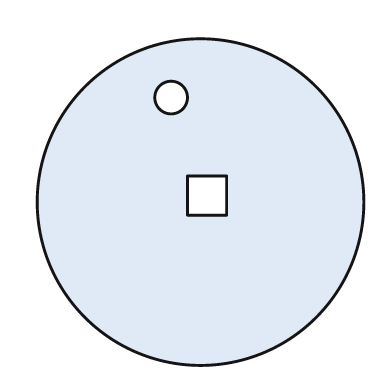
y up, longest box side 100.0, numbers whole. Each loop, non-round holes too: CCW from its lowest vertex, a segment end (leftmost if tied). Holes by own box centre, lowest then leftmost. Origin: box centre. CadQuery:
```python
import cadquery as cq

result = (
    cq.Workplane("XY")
    .moveTo(0.0, 0.0)
    .circle(50.0)
    .moveTo(-4.0, -4.0)
    .lineTo(8.0, -4.0)
    .lineTo(8.0, 8.0)
    .lineTo(-4.0, 8.0)
    .close()
    .moveTo(-9.0, 32.0)
    .circle(5.0)
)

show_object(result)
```